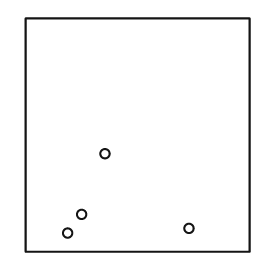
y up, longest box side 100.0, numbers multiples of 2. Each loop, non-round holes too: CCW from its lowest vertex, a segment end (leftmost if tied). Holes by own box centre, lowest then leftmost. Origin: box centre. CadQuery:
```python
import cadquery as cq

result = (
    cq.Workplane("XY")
    .moveTo(-48.0, -50.0)
    .lineTo(48.0, -50.0)
    .lineTo(48.0, 50.0)
    .lineTo(-48.0, 50.0)
    .close()
    .moveTo(-30.0, -42.0)
    .circle(2.0)
    .moveTo(22.0, -40.0)
    .circle(2.0)
    .moveTo(-24.0, -34.0)
    .circle(2.0)
    .moveTo(-14.0, -8.0)
    .circle(2.0)
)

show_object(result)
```